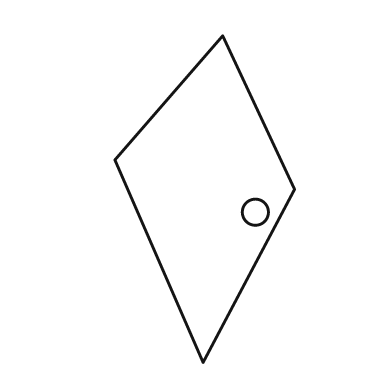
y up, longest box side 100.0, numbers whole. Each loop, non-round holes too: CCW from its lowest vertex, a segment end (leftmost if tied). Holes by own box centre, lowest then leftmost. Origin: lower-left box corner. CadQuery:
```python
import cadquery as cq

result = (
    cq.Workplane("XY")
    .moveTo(27.0, 0.0)
    .lineTo(55.0, 53.0)
    .lineTo(33.0, 100.0)
    .lineTo(0.0, 62.0)
    .close()
    .moveTo(43.0, 46.0)
    .circle(4.0)
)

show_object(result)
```